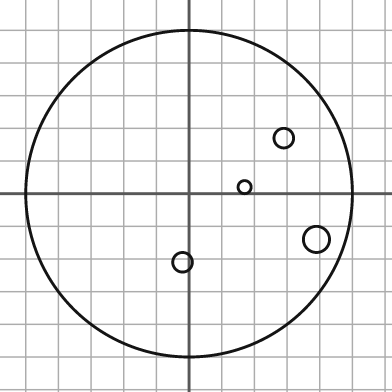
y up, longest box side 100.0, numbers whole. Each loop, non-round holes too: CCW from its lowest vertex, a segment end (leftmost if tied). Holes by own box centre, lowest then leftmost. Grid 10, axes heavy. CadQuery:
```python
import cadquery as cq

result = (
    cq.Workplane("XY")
    .moveTo(0.0, 0.0)
    .circle(50.0)
    .moveTo(-2.0, -21.0)
    .circle(3.0)
    .moveTo(39.0, -14.0)
    .circle(4.0)
    .moveTo(17.0, 2.0)
    .circle(2.0)
    .moveTo(29.0, 17.0)
    .circle(3.0)
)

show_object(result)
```